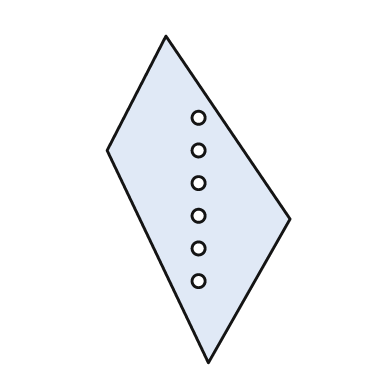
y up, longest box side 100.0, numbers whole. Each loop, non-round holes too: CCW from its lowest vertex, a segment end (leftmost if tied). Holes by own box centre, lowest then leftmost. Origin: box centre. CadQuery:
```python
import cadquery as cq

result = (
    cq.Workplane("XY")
    .moveTo(3.0, -50.0)
    .lineTo(28.0, -6.0)
    .lineTo(-10.0, 50.0)
    .lineTo(-28.0, 15.0)
    .close()
    .moveTo(0.0, -25.0)
    .circle(2.0)
    .moveTo(0.0, -15.0)
    .circle(2.0)
    .moveTo(0.0, -5.0)
    .circle(2.0)
    .moveTo(0.0, 5.0)
    .circle(2.0)
    .moveTo(0.0, 15.0)
    .circle(2.0)
    .moveTo(0.0, 25.0)
    .circle(2.0)
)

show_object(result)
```